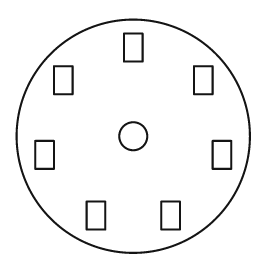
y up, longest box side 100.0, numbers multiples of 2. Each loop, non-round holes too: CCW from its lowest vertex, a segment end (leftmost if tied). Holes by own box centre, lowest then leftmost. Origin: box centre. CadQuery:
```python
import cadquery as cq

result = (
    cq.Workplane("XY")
    .moveTo(0.0, 0.0)
    .circle(50.0)
    .moveTo(-20.0, -40.0)
    .lineTo(-12.0, -40.0)
    .lineTo(-12.0, -28.0)
    .lineTo(-20.0, -28.0)
    .close()
    .moveTo(12.0, -40.0)
    .lineTo(20.0, -40.0)
    .lineTo(20.0, -28.0)
    .lineTo(12.0, -28.0)
    .close()
    .moveTo(-42.0, -14.0)
    .lineTo(-34.0, -14.0)
    .lineTo(-34.0, -2.0)
    .lineTo(-42.0, -2.0)
    .close()
    .moveTo(34.0, -14.0)
    .lineTo(42.0, -14.0)
    .lineTo(42.0, -2.0)
    .lineTo(34.0, -2.0)
    .close()
    .moveTo(0.0, 0.0)
    .circle(6.0)
    .moveTo(-34.0, 18.0)
    .lineTo(-26.0, 18.0)
    .lineTo(-26.0, 30.0)
    .lineTo(-34.0, 30.0)
    .close()
    .moveTo(26.0, 18.0)
    .lineTo(34.0, 18.0)
    .lineTo(34.0, 30.0)
    .lineTo(26.0, 30.0)
    .close()
    .moveTo(-4.0, 32.0)
    .lineTo(4.0, 32.0)
    .lineTo(4.0, 44.0)
    .lineTo(-4.0, 44.0)
    .close()
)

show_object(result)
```